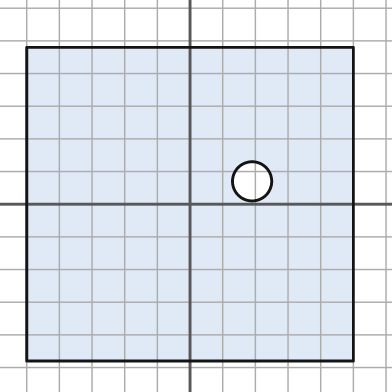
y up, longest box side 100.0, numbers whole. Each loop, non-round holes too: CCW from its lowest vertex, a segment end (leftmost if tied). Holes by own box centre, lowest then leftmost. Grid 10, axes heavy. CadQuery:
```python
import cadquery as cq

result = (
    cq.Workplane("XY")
    .moveTo(-50.0, -48.0)
    .lineTo(50.0, -48.0)
    .lineTo(50.0, 48.0)
    .lineTo(-50.0, 48.0)
    .close()
    .moveTo(19.0, 7.0)
    .circle(6.0)
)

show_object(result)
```